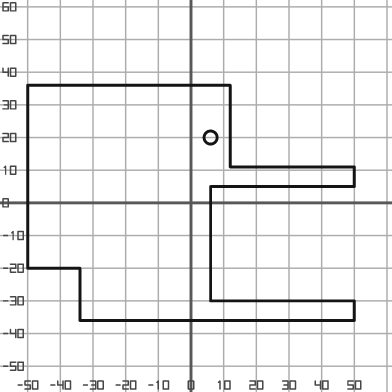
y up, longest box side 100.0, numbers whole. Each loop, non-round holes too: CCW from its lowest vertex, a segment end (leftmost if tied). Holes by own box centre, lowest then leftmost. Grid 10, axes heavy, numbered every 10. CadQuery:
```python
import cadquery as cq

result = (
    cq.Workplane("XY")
    .moveTo(-34.0, -36.0)
    .lineTo(50.0, -36.0)
    .lineTo(50.0, -30.0)
    .lineTo(6.0, -30.0)
    .lineTo(6.0, 5.0)
    .lineTo(50.0, 5.0)
    .lineTo(50.0, 11.0)
    .lineTo(12.0, 11.0)
    .lineTo(12.0, 36.0)
    .lineTo(-50.0, 36.0)
    .lineTo(-50.0, -20.0)
    .lineTo(-34.0, -20.0)
    .close()
    .moveTo(6.0, 20.0)
    .circle(2.0)
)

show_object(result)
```